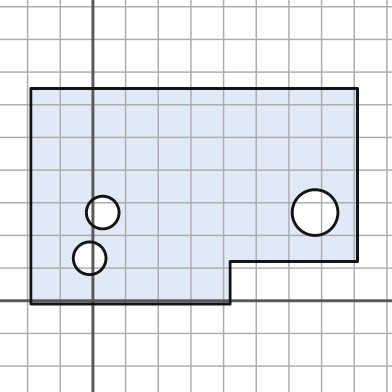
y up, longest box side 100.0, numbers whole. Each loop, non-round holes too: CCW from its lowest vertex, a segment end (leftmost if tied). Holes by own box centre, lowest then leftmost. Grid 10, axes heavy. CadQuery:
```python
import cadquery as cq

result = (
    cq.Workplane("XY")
    .moveTo(-19.0, -1.0)
    .lineTo(42.0, -1.0)
    .lineTo(42.0, 12.0)
    .lineTo(81.0, 12.0)
    .lineTo(81.0, 65.0)
    .lineTo(-19.0, 65.0)
    .close()
    .moveTo(-1.0, 13.0)
    .circle(5.0)
    .moveTo(3.0, 27.0)
    .circle(5.0)
    .moveTo(68.0, 27.0)
    .circle(7.0)
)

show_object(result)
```